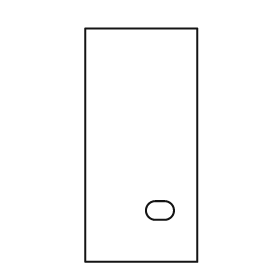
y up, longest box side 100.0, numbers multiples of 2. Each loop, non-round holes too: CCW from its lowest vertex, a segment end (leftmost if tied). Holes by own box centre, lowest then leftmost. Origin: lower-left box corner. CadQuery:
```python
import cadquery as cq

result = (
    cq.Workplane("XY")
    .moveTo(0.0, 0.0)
    .lineTo(48.0, 0.0)
    .lineTo(48.0, 100.0)
    .lineTo(0.0, 100.0)
    .close()
    .moveTo(30.0, 18.0)
    .lineTo(34.0, 18.0)
    .threePointArc((38.0, 22.0), (34.0, 26.0))
    .lineTo(30.0, 26.0)
    .threePointArc((26.0, 22.0), (30.0, 18.0))
    .close()
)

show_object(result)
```